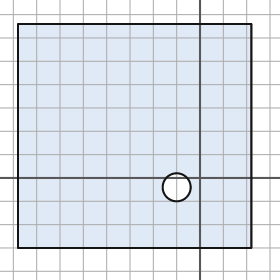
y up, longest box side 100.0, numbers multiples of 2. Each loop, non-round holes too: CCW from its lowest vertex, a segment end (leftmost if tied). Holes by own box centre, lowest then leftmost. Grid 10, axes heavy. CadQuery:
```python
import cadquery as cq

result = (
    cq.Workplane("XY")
    .moveTo(-78.0, -30.0)
    .lineTo(22.0, -30.0)
    .lineTo(22.0, 66.0)
    .lineTo(-78.0, 66.0)
    .close()
    .moveTo(-10.0, -4.0)
    .circle(6.0)
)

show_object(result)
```